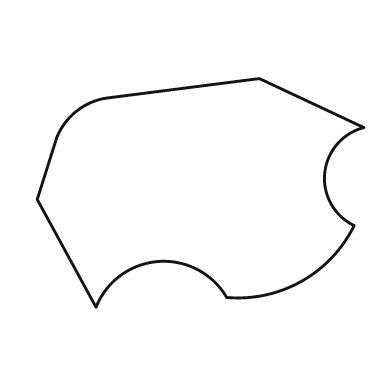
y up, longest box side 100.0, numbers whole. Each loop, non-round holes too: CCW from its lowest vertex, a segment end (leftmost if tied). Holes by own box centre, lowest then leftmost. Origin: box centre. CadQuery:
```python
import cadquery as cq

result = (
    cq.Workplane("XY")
    .moveTo(-32.0, -35.0)
    .threePointArc((-13.0, -21.0), (8.0, -32.0))
    .threePointArc((31.0, -27.0), (47.0, -10.0))
    .threePointArc((38.0, 6.0), (50.0, 20.0))
    .lineTo(18.0, 35.0)
    .lineTo(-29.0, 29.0)
    .threePointArc((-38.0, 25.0), (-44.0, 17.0))
    .lineTo(-50.0, -2.0)
    .close()
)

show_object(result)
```